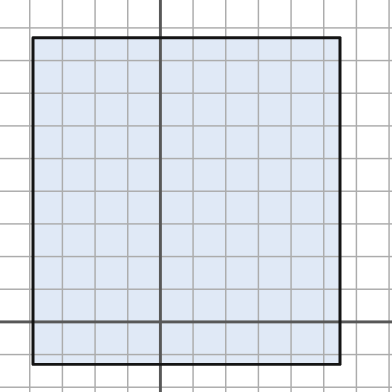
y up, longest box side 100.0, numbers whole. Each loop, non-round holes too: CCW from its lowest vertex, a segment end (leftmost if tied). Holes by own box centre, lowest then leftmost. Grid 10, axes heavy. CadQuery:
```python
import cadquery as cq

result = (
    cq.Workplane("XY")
    .moveTo(-39.0, -13.0)
    .lineTo(55.0, -13.0)
    .lineTo(55.0, 87.0)
    .lineTo(-39.0, 87.0)
    .close()
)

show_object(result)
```